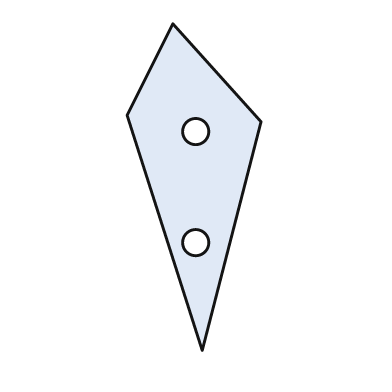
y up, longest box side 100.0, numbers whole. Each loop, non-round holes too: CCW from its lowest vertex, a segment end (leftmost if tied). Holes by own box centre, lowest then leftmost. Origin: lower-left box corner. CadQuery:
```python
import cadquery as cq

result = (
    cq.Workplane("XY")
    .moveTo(23.0, 0.0)
    .lineTo(41.0, 70.0)
    .lineTo(14.0, 100.0)
    .lineTo(0.0, 72.0)
    .close()
    .moveTo(21.0, 33.0)
    .circle(4.0)
    .moveTo(21.0, 67.0)
    .circle(4.0)
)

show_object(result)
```